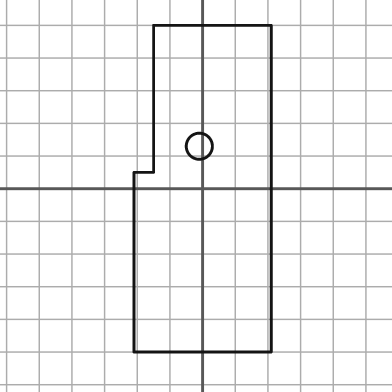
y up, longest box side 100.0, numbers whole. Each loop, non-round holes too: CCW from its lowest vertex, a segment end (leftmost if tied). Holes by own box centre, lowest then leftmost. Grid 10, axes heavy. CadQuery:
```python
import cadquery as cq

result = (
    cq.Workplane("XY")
    .moveTo(-21.0, -50.0)
    .lineTo(21.0, -50.0)
    .lineTo(21.0, 50.0)
    .lineTo(-15.0, 50.0)
    .lineTo(-15.0, 5.0)
    .lineTo(-21.0, 5.0)
    .close()
    .moveTo(-1.0, 13.0)
    .circle(4.0)
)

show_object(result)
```